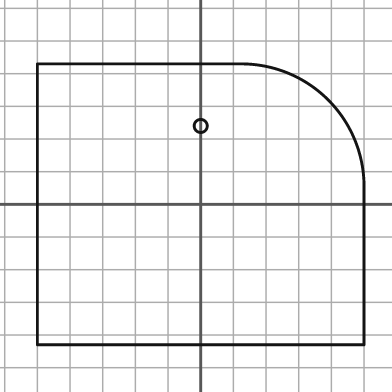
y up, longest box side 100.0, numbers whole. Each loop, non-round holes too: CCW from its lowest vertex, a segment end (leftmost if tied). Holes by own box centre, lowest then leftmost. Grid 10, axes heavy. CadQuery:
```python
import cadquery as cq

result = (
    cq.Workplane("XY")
    .moveTo(-50.0, -43.0)
    .lineTo(50.0, -43.0)
    .lineTo(50.0, 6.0)
    .threePointArc((39.0, 32.0), (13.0, 43.0))
    .lineTo(-50.0, 43.0)
    .close()
    .moveTo(0.0, 24.0)
    .circle(2.0)
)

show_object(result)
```